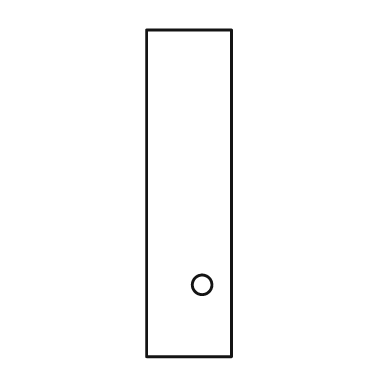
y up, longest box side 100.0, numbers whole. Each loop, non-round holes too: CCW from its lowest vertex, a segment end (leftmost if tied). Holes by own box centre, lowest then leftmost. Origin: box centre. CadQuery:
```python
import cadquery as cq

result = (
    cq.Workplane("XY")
    .moveTo(-13.0, -50.0)
    .lineTo(13.0, -50.0)
    .lineTo(13.0, 50.0)
    .lineTo(-13.0, 50.0)
    .close()
    .moveTo(4.0, -28.0)
    .circle(3.0)
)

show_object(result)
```